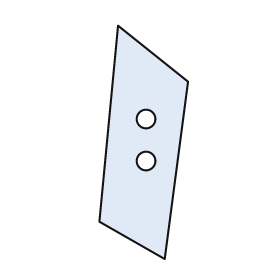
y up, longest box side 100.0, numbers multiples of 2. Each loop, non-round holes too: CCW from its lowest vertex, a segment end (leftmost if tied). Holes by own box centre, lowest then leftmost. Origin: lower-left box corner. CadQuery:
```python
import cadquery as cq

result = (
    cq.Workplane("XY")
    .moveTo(28.0, 0.0)
    .lineTo(38.0, 76.0)
    .lineTo(8.0, 100.0)
    .lineTo(0.0, 16.0)
    .close()
    .moveTo(20.0, 42.0)
    .circle(4.0)
    .moveTo(20.0, 60.0)
    .circle(4.0)
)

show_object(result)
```